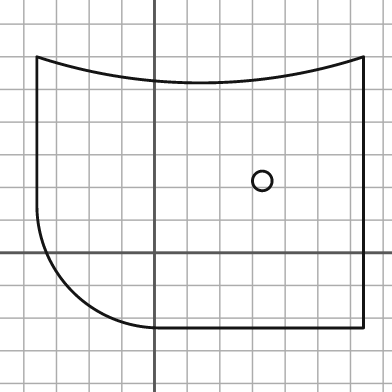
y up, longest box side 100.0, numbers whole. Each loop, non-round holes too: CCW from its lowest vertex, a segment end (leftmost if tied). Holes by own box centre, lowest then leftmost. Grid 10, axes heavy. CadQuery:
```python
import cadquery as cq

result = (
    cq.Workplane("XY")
    .moveTo(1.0, -23.0)
    .lineTo(64.0, -23.0)
    .lineTo(64.0, 60.0)
    .threePointArc((14.0, 52.0), (-36.0, 60.0))
    .lineTo(-36.0, 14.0)
    .threePointArc((-25.0, -12.0), (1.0, -23.0))
    .close()
    .moveTo(33.0, 22.0)
    .circle(3.0)
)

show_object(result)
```